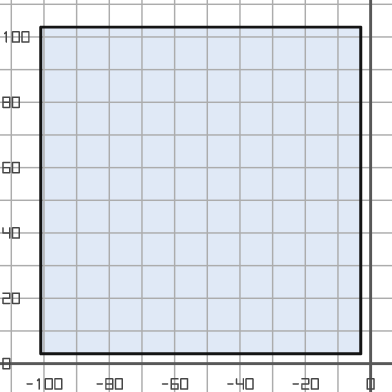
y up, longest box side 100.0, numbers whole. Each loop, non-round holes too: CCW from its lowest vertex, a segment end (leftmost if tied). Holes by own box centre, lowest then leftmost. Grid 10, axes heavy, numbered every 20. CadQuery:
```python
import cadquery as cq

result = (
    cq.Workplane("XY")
    .moveTo(-101.0, 3.0)
    .lineTo(-3.0, 3.0)
    .lineTo(-3.0, 103.0)
    .lineTo(-101.0, 103.0)
    .close()
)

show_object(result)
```